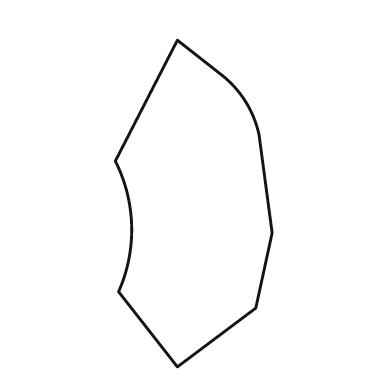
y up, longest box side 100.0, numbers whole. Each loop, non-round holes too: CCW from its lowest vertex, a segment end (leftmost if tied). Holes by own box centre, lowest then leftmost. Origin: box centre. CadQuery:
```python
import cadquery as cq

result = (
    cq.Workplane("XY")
    .moveTo(-5.0, -50.0)
    .lineTo(19.0, -32.0)
    .lineTo(24.0, -9.0)
    .lineTo(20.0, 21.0)
    .threePointArc((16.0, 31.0), (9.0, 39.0))
    .lineTo(-5.0, 50.0)
    .lineTo(-24.0, 13.0)
    .threePointArc((-19.0, -7.0), (-23.0, -27.0))
    .close()
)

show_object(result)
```